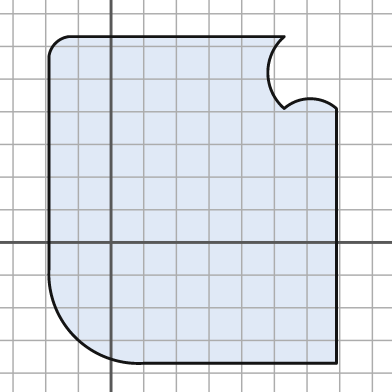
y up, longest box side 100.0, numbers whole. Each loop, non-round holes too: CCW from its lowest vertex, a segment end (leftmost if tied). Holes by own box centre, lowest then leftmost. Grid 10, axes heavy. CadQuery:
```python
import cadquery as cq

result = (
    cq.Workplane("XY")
    .moveTo(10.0, -37.0)
    .lineTo(69.0, -37.0)
    .lineTo(69.0, 41.0)
    .threePointArc((61.0, 44.0), (53.0, 41.0))
    .threePointArc((48.0, 52.0), (53.0, 63.0))
    .lineTo(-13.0, 63.0)
    .threePointArc((-17.0, 61.0), (-19.0, 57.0))
    .lineTo(-19.0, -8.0)
    .threePointArc((-11.0, -29.0), (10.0, -37.0))
    .close()
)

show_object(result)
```